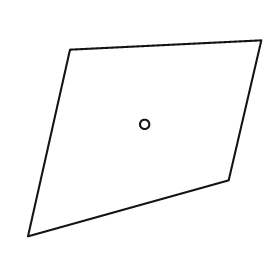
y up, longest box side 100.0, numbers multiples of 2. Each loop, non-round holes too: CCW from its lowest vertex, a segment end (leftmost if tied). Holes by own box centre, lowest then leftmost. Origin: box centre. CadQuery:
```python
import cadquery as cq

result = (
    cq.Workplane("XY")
    .moveTo(-50.0, -42.0)
    .lineTo(36.0, -18.0)
    .lineTo(50.0, 42.0)
    .lineTo(-32.0, 38.0)
    .close()
    .moveTo(0.0, 6.0)
    .circle(2.0)
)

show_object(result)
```